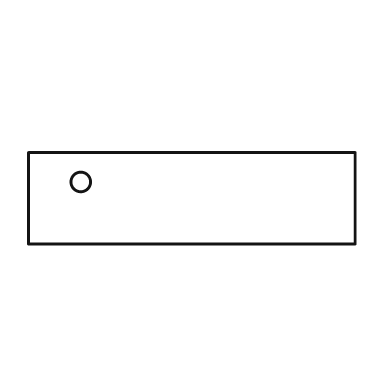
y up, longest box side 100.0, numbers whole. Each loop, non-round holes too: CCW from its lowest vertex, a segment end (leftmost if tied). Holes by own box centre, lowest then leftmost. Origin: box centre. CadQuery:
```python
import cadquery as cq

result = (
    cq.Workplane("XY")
    .moveTo(-50.0, -14.0)
    .lineTo(50.0, -14.0)
    .lineTo(50.0, 14.0)
    .lineTo(-50.0, 14.0)
    .close()
    .moveTo(-34.0, 5.0)
    .circle(3.0)
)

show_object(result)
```